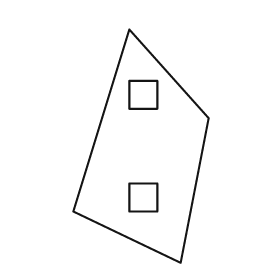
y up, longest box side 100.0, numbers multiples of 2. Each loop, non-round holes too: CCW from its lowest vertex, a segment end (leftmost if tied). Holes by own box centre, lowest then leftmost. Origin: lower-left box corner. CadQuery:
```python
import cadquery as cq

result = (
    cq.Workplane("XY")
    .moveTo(46.0, 0.0)
    .lineTo(58.0, 62.0)
    .lineTo(24.0, 100.0)
    .lineTo(0.0, 22.0)
    .close()
    .moveTo(24.0, 22.0)
    .lineTo(36.0, 22.0)
    .lineTo(36.0, 34.0)
    .lineTo(24.0, 34.0)
    .close()
    .moveTo(24.0, 66.0)
    .lineTo(36.0, 66.0)
    .lineTo(36.0, 78.0)
    .lineTo(24.0, 78.0)
    .close()
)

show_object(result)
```